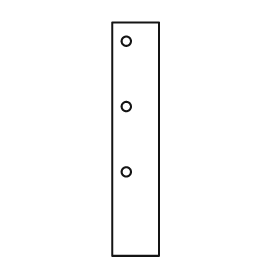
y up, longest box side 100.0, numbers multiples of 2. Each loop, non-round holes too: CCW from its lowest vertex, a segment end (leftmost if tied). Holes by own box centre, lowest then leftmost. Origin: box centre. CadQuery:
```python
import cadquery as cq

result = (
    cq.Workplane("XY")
    .moveTo(-10.0, -50.0)
    .lineTo(10.0, -50.0)
    .lineTo(10.0, 50.0)
    .lineTo(-10.0, 50.0)
    .close()
    .moveTo(-4.0, -14.0)
    .circle(2.0)
    .moveTo(-4.0, 14.0)
    .circle(2.0)
    .moveTo(-4.0, 42.0)
    .circle(2.0)
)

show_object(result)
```